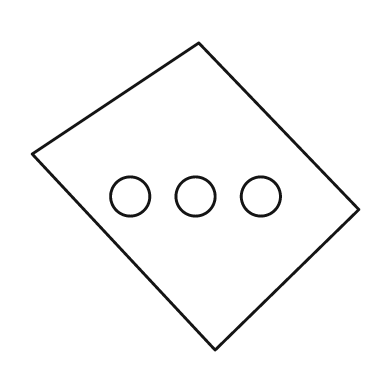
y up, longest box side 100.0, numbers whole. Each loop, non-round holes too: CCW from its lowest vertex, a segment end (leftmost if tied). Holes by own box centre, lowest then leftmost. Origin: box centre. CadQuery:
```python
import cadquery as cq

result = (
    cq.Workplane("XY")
    .moveTo(6.0, -47.0)
    .lineTo(50.0, -4.0)
    .lineTo(1.0, 47.0)
    .lineTo(-50.0, 13.0)
    .close()
    .moveTo(-20.0, 0.0)
    .circle(6.0)
    .moveTo(0.0, 0.0)
    .circle(6.0)
    .moveTo(20.0, 0.0)
    .circle(6.0)
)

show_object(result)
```